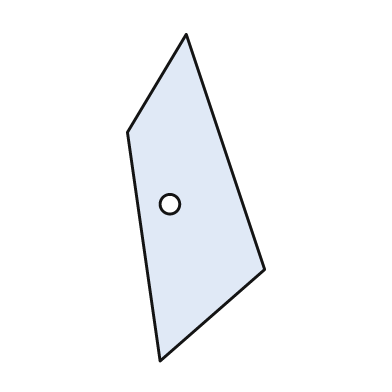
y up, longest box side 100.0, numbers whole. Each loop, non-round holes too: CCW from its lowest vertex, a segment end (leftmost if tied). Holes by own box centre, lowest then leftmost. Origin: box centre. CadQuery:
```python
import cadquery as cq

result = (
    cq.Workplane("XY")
    .moveTo(-11.0, -50.0)
    .lineTo(21.0, -22.0)
    .lineTo(-3.0, 50.0)
    .lineTo(-21.0, 20.0)
    .close()
    .moveTo(-8.0, -2.0)
    .circle(3.0)
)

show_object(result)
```